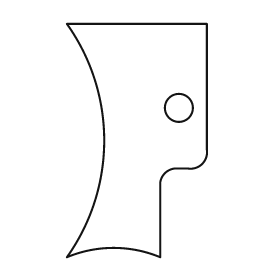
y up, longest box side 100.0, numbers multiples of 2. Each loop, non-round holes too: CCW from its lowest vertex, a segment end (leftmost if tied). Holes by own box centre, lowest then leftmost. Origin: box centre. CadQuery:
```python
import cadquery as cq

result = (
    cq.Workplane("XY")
    .moveTo(-30.0, -50.0)
    .threePointArc((-10.0, -46.0), (10.0, -50.0))
    .lineTo(10.0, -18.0)
    .threePointArc((12.0, -14.0), (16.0, -12.0))
    .lineTo(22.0, -12.0)
    .threePointArc((28.0, -10.0), (30.0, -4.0))
    .lineTo(30.0, 50.0)
    .lineTo(-30.0, 50.0)
    .threePointArc((-14.0, 0.0), (-30.0, -50.0))
    .close()
    .moveTo(18.0, 14.0)
    .circle(6.0)
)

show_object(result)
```